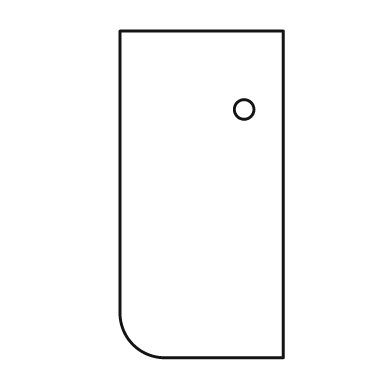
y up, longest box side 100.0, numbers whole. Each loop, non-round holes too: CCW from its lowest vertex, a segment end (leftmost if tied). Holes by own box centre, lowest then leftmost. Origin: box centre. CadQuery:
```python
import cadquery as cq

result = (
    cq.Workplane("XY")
    .moveTo(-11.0, -50.0)
    .lineTo(25.0, -50.0)
    .lineTo(25.0, 50.0)
    .lineTo(-25.0, 50.0)
    .lineTo(-25.0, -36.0)
    .threePointArc((-21.0, -46.0), (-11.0, -50.0))
    .close()
    .moveTo(13.0, 26.0)
    .circle(3.0)
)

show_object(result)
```